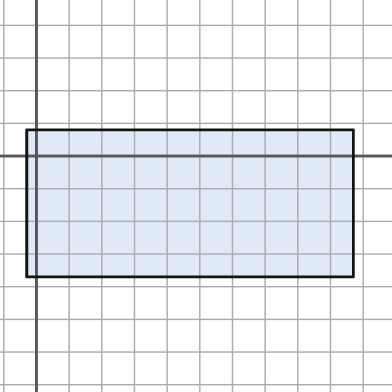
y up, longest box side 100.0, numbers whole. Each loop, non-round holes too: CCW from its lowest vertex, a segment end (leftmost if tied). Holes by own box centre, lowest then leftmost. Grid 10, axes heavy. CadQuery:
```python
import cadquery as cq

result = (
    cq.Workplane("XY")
    .moveTo(-3.0, -37.0)
    .lineTo(97.0, -37.0)
    .lineTo(97.0, 8.0)
    .lineTo(-3.0, 8.0)
    .close()
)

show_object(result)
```